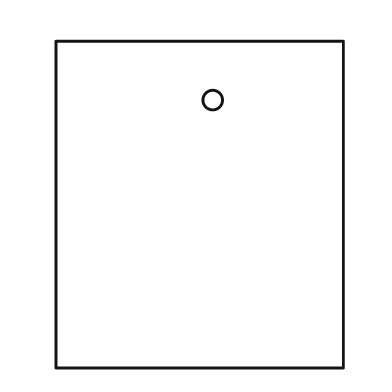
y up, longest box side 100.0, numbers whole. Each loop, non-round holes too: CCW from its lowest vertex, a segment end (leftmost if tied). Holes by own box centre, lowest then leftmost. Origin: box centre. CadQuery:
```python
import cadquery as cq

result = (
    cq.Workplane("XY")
    .moveTo(-44.0, -50.0)
    .lineTo(44.0, -50.0)
    .lineTo(44.0, 50.0)
    .lineTo(-44.0, 50.0)
    .close()
    .moveTo(4.0, 32.0)
    .circle(3.0)
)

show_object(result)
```